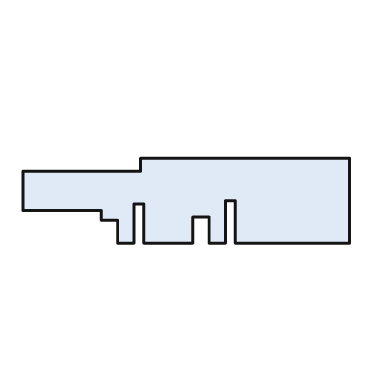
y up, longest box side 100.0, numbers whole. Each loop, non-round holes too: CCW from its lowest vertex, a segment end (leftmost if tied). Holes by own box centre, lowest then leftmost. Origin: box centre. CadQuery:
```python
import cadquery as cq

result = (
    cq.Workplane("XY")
    .moveTo(-21.0, -13.0)
    .lineTo(-16.0, -13.0)
    .lineTo(-16.0, -1.0)
    .lineTo(-13.0, -1.0)
    .lineTo(-13.0, -13.0)
    .lineTo(2.0, -13.0)
    .lineTo(2.0, -5.0)
    .lineTo(7.0, -5.0)
    .lineTo(7.0, -13.0)
    .lineTo(12.0, -13.0)
    .lineTo(12.0, 0.0)
    .lineTo(15.0, 0.0)
    .lineTo(15.0, -13.0)
    .lineTo(50.0, -13.0)
    .lineTo(50.0, 13.0)
    .lineTo(-14.0, 13.0)
    .lineTo(-14.0, 9.0)
    .lineTo(-50.0, 9.0)
    .lineTo(-50.0, -3.0)
    .lineTo(-26.0, -3.0)
    .lineTo(-26.0, -6.0)
    .lineTo(-21.0, -6.0)
    .close()
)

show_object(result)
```